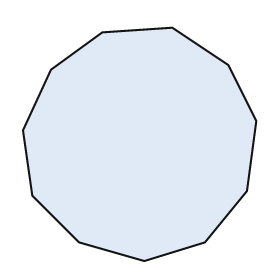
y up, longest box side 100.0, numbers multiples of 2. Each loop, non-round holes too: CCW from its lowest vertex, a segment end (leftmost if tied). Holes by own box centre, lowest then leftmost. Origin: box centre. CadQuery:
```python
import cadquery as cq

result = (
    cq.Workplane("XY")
    .moveTo(2.0, -50.0)
    .lineTo(28.0, -42.0)
    .lineTo(46.0, -20.0)
    .lineTo(50.0, 10.0)
    .lineTo(38.0, 34.0)
    .lineTo(14.0, 50.0)
    .lineTo(-16.0, 48.0)
    .lineTo(-38.0, 32.0)
    .lineTo(-50.0, 6.0)
    .lineTo(-46.0, -22.0)
    .lineTo(-26.0, -42.0)
    .close()
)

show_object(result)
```